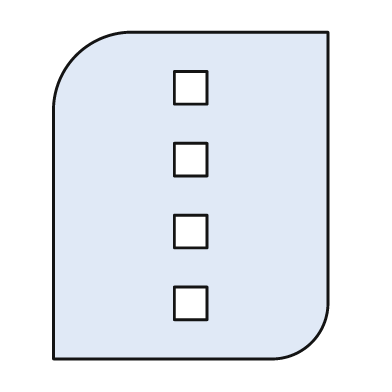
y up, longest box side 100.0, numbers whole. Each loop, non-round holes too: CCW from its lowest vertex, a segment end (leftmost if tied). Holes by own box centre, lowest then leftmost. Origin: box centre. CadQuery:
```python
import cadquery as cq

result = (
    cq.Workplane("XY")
    .moveTo(-42.0, -50.0)
    .lineTo(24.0, -50.0)
    .threePointArc((37.0, -45.0), (42.0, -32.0))
    .lineTo(42.0, 50.0)
    .lineTo(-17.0, 50.0)
    .threePointArc((-35.0, 43.0), (-42.0, 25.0))
    .close()
    .moveTo(-5.0, -38.0)
    .lineTo(5.0, -38.0)
    .lineTo(5.0, -28.0)
    .lineTo(-5.0, -28.0)
    .close()
    .moveTo(-5.0, -16.0)
    .lineTo(5.0, -16.0)
    .lineTo(5.0, -6.0)
    .lineTo(-5.0, -6.0)
    .close()
    .moveTo(-5.0, 6.0)
    .lineTo(5.0, 6.0)
    .lineTo(5.0, 16.0)
    .lineTo(-5.0, 16.0)
    .close()
    .moveTo(-5.0, 28.0)
    .lineTo(5.0, 28.0)
    .lineTo(5.0, 38.0)
    .lineTo(-5.0, 38.0)
    .close()
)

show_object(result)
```